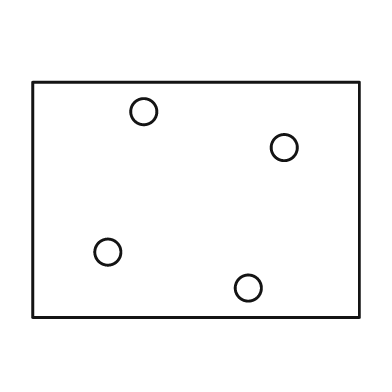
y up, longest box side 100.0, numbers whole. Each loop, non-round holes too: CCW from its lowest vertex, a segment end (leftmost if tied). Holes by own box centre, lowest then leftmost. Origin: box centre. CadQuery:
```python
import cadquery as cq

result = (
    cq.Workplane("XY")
    .moveTo(-50.0, -36.0)
    .lineTo(50.0, -36.0)
    .lineTo(50.0, 36.0)
    .lineTo(-50.0, 36.0)
    .close()
    .moveTo(16.0, -27.0)
    .circle(4.0)
    .moveTo(-27.0, -16.0)
    .circle(4.0)
    .moveTo(27.0, 16.0)
    .circle(4.0)
    .moveTo(-16.0, 27.0)
    .circle(4.0)
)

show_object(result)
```